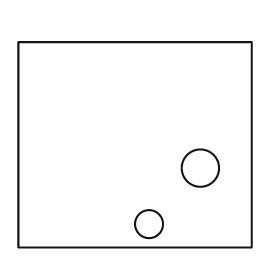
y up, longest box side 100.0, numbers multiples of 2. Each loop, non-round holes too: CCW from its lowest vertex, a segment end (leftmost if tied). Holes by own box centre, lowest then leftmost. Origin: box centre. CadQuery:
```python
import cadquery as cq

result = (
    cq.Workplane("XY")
    .moveTo(-50.0, -44.0)
    .lineTo(50.0, -44.0)
    .lineTo(50.0, 44.0)
    .lineTo(-50.0, 44.0)
    .close()
    .moveTo(6.0, -34.0)
    .circle(6.0)
    .moveTo(28.0, -10.0)
    .circle(8.0)
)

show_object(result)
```